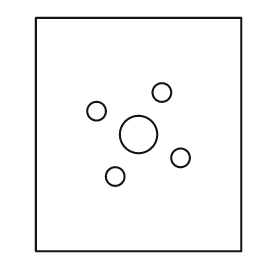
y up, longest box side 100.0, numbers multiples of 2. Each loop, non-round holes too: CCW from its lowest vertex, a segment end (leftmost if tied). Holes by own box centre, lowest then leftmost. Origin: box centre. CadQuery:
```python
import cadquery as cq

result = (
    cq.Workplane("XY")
    .moveTo(-44.0, -50.0)
    .lineTo(44.0, -50.0)
    .lineTo(44.0, 50.0)
    .lineTo(-44.0, 50.0)
    .close()
    .moveTo(-10.0, -18.0)
    .circle(4.0)
    .moveTo(18.0, -10.0)
    .circle(4.0)
    .moveTo(0.0, 0.0)
    .circle(8.0)
    .moveTo(-18.0, 10.0)
    .circle(4.0)
    .moveTo(10.0, 18.0)
    .circle(4.0)
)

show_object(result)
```